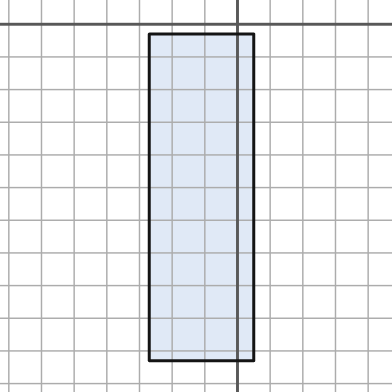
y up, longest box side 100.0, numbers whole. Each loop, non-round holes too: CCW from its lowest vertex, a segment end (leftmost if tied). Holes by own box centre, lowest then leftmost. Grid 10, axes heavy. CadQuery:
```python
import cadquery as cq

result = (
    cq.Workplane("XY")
    .moveTo(-27.0, -103.0)
    .lineTo(5.0, -103.0)
    .lineTo(5.0, -3.0)
    .lineTo(-27.0, -3.0)
    .close()
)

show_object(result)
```